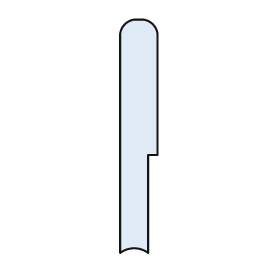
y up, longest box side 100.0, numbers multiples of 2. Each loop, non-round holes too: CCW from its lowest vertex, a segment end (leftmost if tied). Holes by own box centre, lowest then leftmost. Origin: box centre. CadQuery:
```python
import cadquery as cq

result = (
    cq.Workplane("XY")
    .moveTo(-8.0, -50.0)
    .threePointArc((-2.0, -48.0), (4.0, -50.0))
    .lineTo(4.0, -8.0)
    .lineTo(8.0, -8.0)
    .lineTo(8.0, 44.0)
    .threePointArc((6.0, 48.0), (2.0, 50.0))
    .lineTo(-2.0, 50.0)
    .threePointArc((-6.0, 48.0), (-8.0, 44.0))
    .close()
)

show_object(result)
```